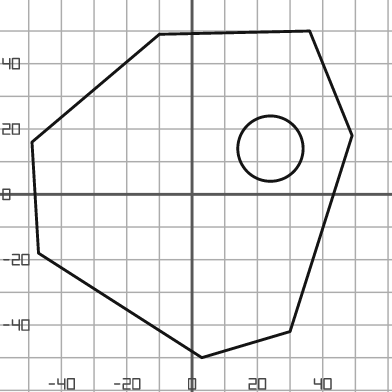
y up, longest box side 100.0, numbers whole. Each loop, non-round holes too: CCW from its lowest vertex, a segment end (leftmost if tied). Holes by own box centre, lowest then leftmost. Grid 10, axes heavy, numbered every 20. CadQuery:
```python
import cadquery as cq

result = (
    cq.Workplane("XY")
    .moveTo(3.0, -50.0)
    .lineTo(30.0, -42.0)
    .lineTo(49.0, 18.0)
    .lineTo(36.0, 50.0)
    .lineTo(-10.0, 49.0)
    .lineTo(-49.0, 16.0)
    .lineTo(-47.0, -18.0)
    .close()
    .moveTo(24.0, 14.0)
    .circle(10.0)
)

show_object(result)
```